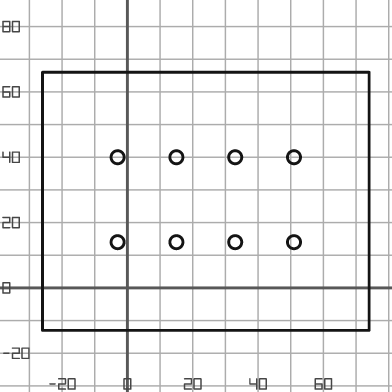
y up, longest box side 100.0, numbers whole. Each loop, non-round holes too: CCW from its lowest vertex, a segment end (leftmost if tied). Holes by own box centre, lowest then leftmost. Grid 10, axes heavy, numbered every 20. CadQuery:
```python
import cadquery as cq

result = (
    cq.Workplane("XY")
    .moveTo(-26.0, -13.0)
    .lineTo(74.0, -13.0)
    .lineTo(74.0, 66.0)
    .lineTo(-26.0, 66.0)
    .close()
    .moveTo(-3.0, 14.0)
    .circle(2.0)
    .moveTo(15.0, 14.0)
    .circle(2.0)
    .moveTo(33.0, 14.0)
    .circle(2.0)
    .moveTo(51.0, 14.0)
    .circle(2.0)
    .moveTo(-3.0, 40.0)
    .circle(2.0)
    .moveTo(15.0, 40.0)
    .circle(2.0)
    .moveTo(33.0, 40.0)
    .circle(2.0)
    .moveTo(51.0, 40.0)
    .circle(2.0)
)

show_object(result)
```